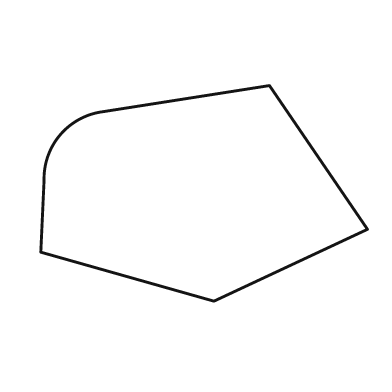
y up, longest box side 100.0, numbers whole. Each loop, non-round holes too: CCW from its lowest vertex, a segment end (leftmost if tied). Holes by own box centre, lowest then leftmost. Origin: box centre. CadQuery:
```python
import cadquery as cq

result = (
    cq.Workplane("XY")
    .moveTo(3.0, -33.0)
    .lineTo(50.0, -11.0)
    .lineTo(20.0, 33.0)
    .lineTo(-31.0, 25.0)
    .threePointArc((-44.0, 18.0), (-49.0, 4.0))
    .lineTo(-50.0, -18.0)
    .close()
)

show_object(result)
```